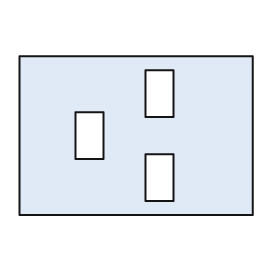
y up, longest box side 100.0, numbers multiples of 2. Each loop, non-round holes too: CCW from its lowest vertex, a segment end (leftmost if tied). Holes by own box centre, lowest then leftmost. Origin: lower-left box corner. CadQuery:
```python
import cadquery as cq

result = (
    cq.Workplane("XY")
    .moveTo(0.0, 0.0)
    .lineTo(100.0, 0.0)
    .lineTo(100.0, 68.0)
    .lineTo(0.0, 68.0)
    .close()
    .moveTo(54.0, 6.0)
    .lineTo(66.0, 6.0)
    .lineTo(66.0, 26.0)
    .lineTo(54.0, 26.0)
    .close()
    .moveTo(24.0, 24.0)
    .lineTo(36.0, 24.0)
    .lineTo(36.0, 44.0)
    .lineTo(24.0, 44.0)
    .close()
    .moveTo(54.0, 42.0)
    .lineTo(66.0, 42.0)
    .lineTo(66.0, 62.0)
    .lineTo(54.0, 62.0)
    .close()
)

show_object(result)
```